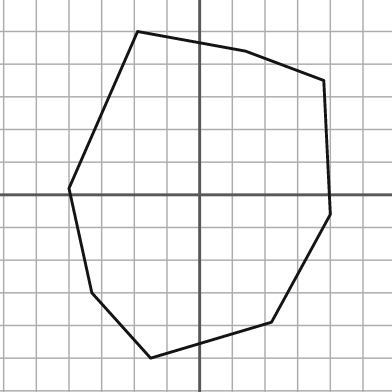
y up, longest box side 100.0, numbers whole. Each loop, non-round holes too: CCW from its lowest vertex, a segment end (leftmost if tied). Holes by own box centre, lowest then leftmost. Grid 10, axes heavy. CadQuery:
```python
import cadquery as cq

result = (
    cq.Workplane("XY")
    .moveTo(-15.0, -50.0)
    .lineTo(22.0, -39.0)
    .lineTo(40.0, -6.0)
    .lineTo(38.0, 35.0)
    .lineTo(14.0, 44.0)
    .lineTo(-19.0, 50.0)
    .lineTo(-40.0, 2.0)
    .lineTo(-33.0, -30.0)
    .close()
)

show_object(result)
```